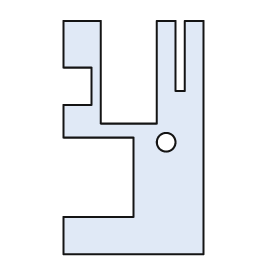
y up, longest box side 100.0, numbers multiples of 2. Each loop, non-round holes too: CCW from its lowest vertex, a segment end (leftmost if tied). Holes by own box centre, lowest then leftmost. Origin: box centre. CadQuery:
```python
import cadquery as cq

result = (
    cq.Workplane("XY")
    .moveTo(-30.0, -50.0)
    .lineTo(30.0, -50.0)
    .lineTo(30.0, 50.0)
    .lineTo(22.0, 50.0)
    .lineTo(22.0, 20.0)
    .lineTo(18.0, 20.0)
    .lineTo(18.0, 50.0)
    .lineTo(10.0, 50.0)
    .lineTo(10.0, 6.0)
    .lineTo(-14.0, 6.0)
    .lineTo(-14.0, 50.0)
    .lineTo(-30.0, 50.0)
    .lineTo(-30.0, 30.0)
    .lineTo(-18.0, 30.0)
    .lineTo(-18.0, 14.0)
    .lineTo(-30.0, 14.0)
    .lineTo(-30.0, 0.0)
    .lineTo(0.0, 0.0)
    .lineTo(0.0, -34.0)
    .lineTo(-30.0, -34.0)
    .close()
    .moveTo(14.0, -2.0)
    .circle(4.0)
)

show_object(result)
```